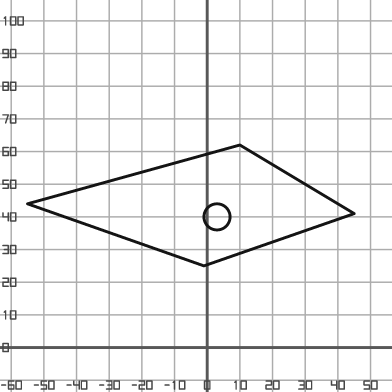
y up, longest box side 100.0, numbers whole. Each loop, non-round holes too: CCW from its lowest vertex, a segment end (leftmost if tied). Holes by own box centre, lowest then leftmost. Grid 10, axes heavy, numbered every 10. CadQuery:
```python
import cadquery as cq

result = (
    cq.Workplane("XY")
    .moveTo(-1.0, 25.0)
    .lineTo(45.0, 41.0)
    .lineTo(10.0, 62.0)
    .lineTo(-55.0, 44.0)
    .close()
    .moveTo(3.0, 40.0)
    .circle(4.0)
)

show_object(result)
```